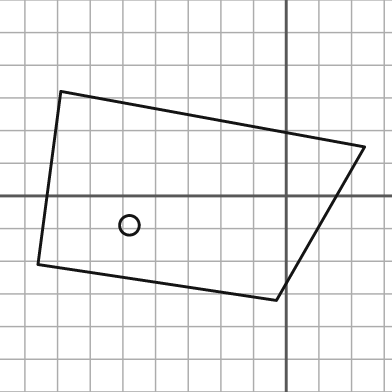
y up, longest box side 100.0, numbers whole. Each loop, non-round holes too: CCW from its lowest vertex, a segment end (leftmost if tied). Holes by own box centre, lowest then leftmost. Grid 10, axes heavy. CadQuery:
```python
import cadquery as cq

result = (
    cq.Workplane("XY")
    .moveTo(-3.0, -32.0)
    .lineTo(24.0, 15.0)
    .lineTo(-69.0, 32.0)
    .lineTo(-76.0, -21.0)
    .close()
    .moveTo(-48.0, -9.0)
    .circle(3.0)
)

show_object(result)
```